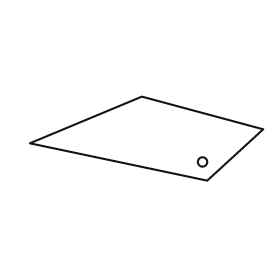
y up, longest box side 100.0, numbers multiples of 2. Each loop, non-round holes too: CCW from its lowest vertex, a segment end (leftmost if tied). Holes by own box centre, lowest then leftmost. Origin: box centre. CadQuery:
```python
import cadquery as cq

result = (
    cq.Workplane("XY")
    .moveTo(26.0, -18.0)
    .lineTo(50.0, 4.0)
    .lineTo(-2.0, 18.0)
    .lineTo(-50.0, -2.0)
    .close()
    .moveTo(24.0, -10.0)
    .circle(2.0)
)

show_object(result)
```